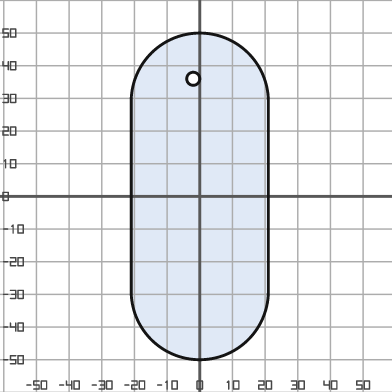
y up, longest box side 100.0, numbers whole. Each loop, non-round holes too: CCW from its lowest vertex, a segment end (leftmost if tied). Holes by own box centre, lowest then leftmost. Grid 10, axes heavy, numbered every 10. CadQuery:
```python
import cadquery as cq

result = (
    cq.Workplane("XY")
    .moveTo(-21.0, -29.0)
    .threePointArc((0.0, -50.0), (21.0, -29.0))
    .lineTo(21.0, 29.0)
    .threePointArc((0.0, 50.0), (-21.0, 29.0))
    .close()
    .moveTo(-2.0, 36.0)
    .circle(2.0)
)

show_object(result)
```